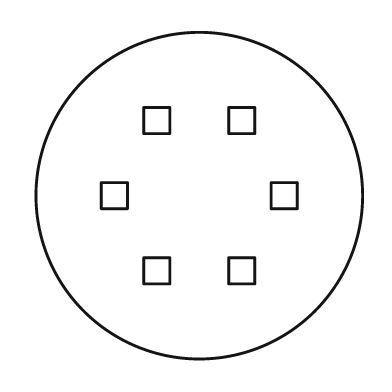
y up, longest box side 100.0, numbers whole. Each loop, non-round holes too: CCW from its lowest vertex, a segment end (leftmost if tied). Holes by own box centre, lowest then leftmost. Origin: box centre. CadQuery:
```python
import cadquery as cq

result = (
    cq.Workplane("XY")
    .moveTo(0.0, 0.0)
    .circle(50.0)
    .moveTo(-17.0, -27.0)
    .lineTo(-9.0, -27.0)
    .lineTo(-9.0, -19.0)
    .lineTo(-17.0, -19.0)
    .close()
    .moveTo(9.0, -27.0)
    .lineTo(17.0, -27.0)
    .lineTo(17.0, -19.0)
    .lineTo(9.0, -19.0)
    .close()
    .moveTo(-30.0, -4.0)
    .lineTo(-22.0, -4.0)
    .lineTo(-22.0, 4.0)
    .lineTo(-30.0, 4.0)
    .close()
    .moveTo(22.0, -4.0)
    .lineTo(30.0, -4.0)
    .lineTo(30.0, 4.0)
    .lineTo(22.0, 4.0)
    .close()
    .moveTo(-17.0, 19.0)
    .lineTo(-9.0, 19.0)
    .lineTo(-9.0, 27.0)
    .lineTo(-17.0, 27.0)
    .close()
    .moveTo(9.0, 19.0)
    .lineTo(17.0, 19.0)
    .lineTo(17.0, 27.0)
    .lineTo(9.0, 27.0)
    .close()
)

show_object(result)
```